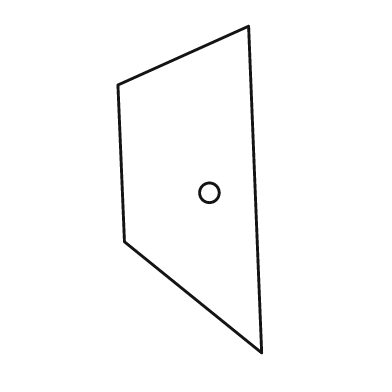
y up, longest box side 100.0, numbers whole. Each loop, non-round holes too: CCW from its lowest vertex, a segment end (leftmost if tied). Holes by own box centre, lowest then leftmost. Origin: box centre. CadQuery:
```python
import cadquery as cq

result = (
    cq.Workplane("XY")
    .moveTo(22.0, -50.0)
    .lineTo(18.0, 50.0)
    .lineTo(-22.0, 32.0)
    .lineTo(-20.0, -16.0)
    .close()
    .moveTo(6.0, -1.0)
    .circle(3.0)
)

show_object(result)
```